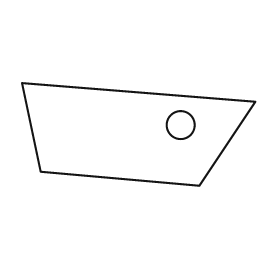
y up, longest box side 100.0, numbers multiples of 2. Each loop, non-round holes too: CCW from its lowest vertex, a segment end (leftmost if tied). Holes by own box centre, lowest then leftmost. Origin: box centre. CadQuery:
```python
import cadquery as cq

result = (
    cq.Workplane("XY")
    .moveTo(26.0, -22.0)
    .lineTo(50.0, 14.0)
    .lineTo(-50.0, 22.0)
    .lineTo(-42.0, -16.0)
    .close()
    .moveTo(18.0, 4.0)
    .circle(6.0)
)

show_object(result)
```